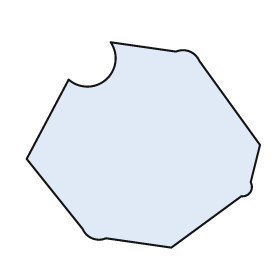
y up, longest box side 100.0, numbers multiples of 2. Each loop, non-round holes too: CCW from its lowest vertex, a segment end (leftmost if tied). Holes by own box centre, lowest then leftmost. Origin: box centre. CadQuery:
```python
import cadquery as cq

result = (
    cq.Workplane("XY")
    .moveTo(12.0, -44.0)
    .lineTo(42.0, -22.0)
    .threePointArc((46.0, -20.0), (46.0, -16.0))
    .lineTo(50.0, 0.0)
    .lineTo(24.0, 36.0)
    .threePointArc((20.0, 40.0), (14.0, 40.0))
    .lineTo(-14.0, 44.0)
    .threePointArc((-16.0, 28.0), (-32.0, 28.0))
    .lineTo(-50.0, -6.0)
    .lineTo(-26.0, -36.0)
    .threePointArc((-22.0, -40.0), (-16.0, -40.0))
    .close()
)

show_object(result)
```